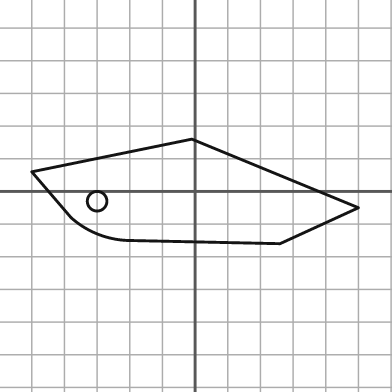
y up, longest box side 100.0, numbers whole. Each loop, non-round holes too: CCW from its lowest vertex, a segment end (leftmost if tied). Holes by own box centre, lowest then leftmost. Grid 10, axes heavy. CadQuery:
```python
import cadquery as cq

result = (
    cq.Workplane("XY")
    .moveTo(26.0, -16.0)
    .lineTo(50.0, -5.0)
    .lineTo(-1.0, 16.0)
    .lineTo(-50.0, 6.0)
    .lineTo(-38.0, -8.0)
    .threePointArc((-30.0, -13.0), (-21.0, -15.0))
    .close()
    .moveTo(-30.0, -3.0)
    .circle(3.0)
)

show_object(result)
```